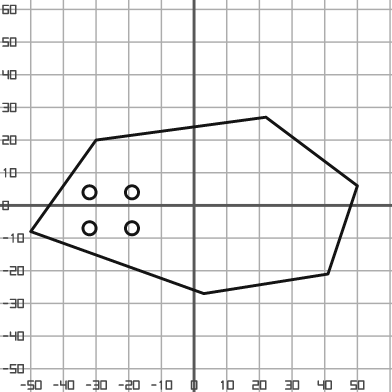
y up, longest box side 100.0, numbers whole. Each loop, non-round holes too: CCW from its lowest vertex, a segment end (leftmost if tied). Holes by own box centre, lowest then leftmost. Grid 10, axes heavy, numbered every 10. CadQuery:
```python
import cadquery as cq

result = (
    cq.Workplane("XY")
    .moveTo(3.0, -27.0)
    .lineTo(41.0, -21.0)
    .lineTo(50.0, 6.0)
    .lineTo(22.0, 27.0)
    .lineTo(-30.0, 20.0)
    .lineTo(-50.0, -8.0)
    .close()
    .moveTo(-32.0, -7.0)
    .circle(2.0)
    .moveTo(-19.0, -7.0)
    .circle(2.0)
    .moveTo(-32.0, 4.0)
    .circle(2.0)
    .moveTo(-19.0, 4.0)
    .circle(2.0)
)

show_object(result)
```